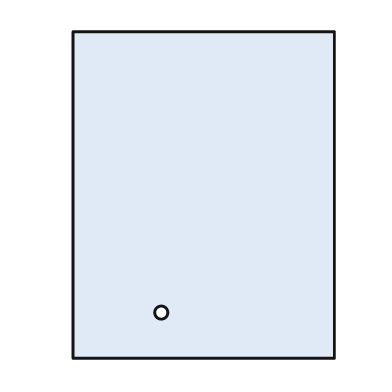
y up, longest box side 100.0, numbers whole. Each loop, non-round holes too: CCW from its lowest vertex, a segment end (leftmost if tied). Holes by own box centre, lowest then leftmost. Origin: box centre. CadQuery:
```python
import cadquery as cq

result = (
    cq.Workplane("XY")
    .moveTo(-40.0, -50.0)
    .lineTo(40.0, -50.0)
    .lineTo(40.0, 50.0)
    .lineTo(-40.0, 50.0)
    .close()
    .moveTo(-13.0, -36.0)
    .circle(2.0)
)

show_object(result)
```